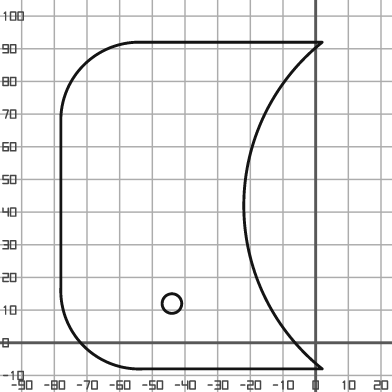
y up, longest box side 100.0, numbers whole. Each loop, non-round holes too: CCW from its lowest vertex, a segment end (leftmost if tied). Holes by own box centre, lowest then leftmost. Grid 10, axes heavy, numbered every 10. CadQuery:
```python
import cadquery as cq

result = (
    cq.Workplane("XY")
    .moveTo(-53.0, -8.0)
    .lineTo(2.0, -8.0)
    .threePointArc((-22.0, 42.0), (2.0, 92.0))
    .lineTo(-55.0, 92.0)
    .threePointArc((-71.0, 85.0), (-78.0, 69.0))
    .lineTo(-78.0, 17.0)
    .threePointArc((-71.0, -1.0), (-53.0, -8.0))
    .close()
    .moveTo(-44.0, 12.0)
    .circle(3.0)
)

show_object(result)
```